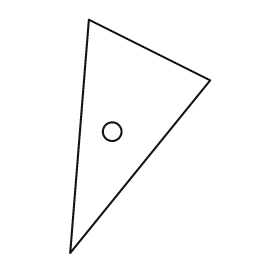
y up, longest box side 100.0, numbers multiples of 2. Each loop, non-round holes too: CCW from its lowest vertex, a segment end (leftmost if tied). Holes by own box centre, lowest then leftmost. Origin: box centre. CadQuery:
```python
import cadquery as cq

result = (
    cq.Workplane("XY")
    .moveTo(-30.0, -50.0)
    .lineTo(30.0, 24.0)
    .lineTo(-22.0, 50.0)
    .close()
    .moveTo(-12.0, 2.0)
    .circle(4.0)
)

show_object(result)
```